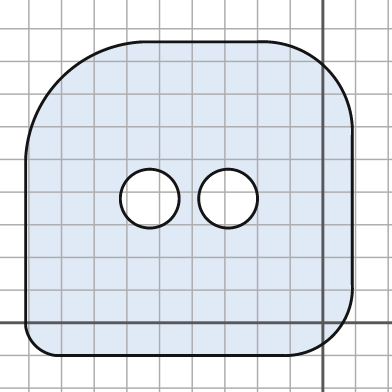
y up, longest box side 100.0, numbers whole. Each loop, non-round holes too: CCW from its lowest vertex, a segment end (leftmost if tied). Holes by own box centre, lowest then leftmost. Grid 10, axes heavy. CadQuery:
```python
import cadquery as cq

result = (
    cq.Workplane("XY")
    .moveTo(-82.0, -10.0)
    .lineTo(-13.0, -10.0)
    .threePointArc((3.0, -4.0), (9.0, 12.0))
    .lineTo(9.0, 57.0)
    .threePointArc((1.0, 78.0), (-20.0, 86.0))
    .lineTo(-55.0, 86.0)
    .threePointArc((-80.0, 75.0), (-91.0, 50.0))
    .lineTo(-91.0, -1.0)
    .threePointArc((-88.0, -7.0), (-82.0, -10.0))
    .close()
    .moveTo(-53.0, 38.0)
    .circle(9.0)
    .moveTo(-29.0, 38.0)
    .circle(9.0)
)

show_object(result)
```